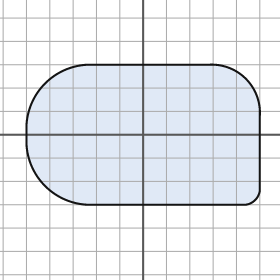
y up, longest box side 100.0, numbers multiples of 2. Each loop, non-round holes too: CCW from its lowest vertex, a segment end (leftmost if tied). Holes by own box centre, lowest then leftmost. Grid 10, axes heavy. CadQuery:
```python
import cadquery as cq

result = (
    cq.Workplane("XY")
    .moveTo(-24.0, -30.0)
    .lineTo(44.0, -30.0)
    .threePointArc((48.0, -28.0), (50.0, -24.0))
    .lineTo(50.0, 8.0)
    .threePointArc((44.0, 24.0), (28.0, 30.0))
    .lineTo(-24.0, 30.0)
    .threePointArc((-42.0, 22.0), (-50.0, 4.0))
    .lineTo(-50.0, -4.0)
    .threePointArc((-42.0, -22.0), (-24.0, -30.0))
    .close()
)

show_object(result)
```